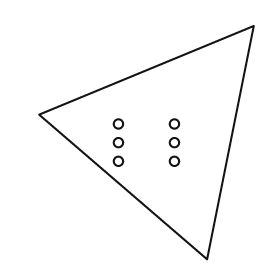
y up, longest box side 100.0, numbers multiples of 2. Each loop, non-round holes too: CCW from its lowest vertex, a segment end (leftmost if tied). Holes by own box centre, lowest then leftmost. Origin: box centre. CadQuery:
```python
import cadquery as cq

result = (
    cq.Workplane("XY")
    .moveTo(26.0, -50.0)
    .lineTo(46.0, 50.0)
    .lineTo(-46.0, 12.0)
    .close()
    .moveTo(-12.0, -8.0)
    .circle(2.0)
    .moveTo(12.0, -8.0)
    .circle(2.0)
    .moveTo(-12.0, 0.0)
    .circle(2.0)
    .moveTo(12.0, 0.0)
    .circle(2.0)
    .moveTo(-12.0, 8.0)
    .circle(2.0)
    .moveTo(12.0, 8.0)
    .circle(2.0)
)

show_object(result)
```